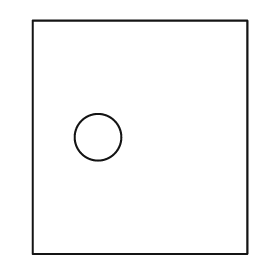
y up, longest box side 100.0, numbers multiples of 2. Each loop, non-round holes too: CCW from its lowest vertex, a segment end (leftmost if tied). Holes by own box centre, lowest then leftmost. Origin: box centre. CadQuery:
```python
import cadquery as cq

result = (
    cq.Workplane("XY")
    .moveTo(-46.0, -50.0)
    .lineTo(46.0, -50.0)
    .lineTo(46.0, 50.0)
    .lineTo(-46.0, 50.0)
    .close()
    .moveTo(-18.0, 0.0)
    .circle(10.0)
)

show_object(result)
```